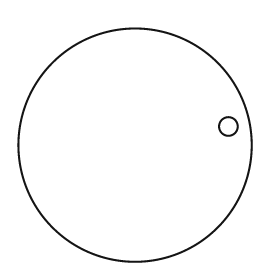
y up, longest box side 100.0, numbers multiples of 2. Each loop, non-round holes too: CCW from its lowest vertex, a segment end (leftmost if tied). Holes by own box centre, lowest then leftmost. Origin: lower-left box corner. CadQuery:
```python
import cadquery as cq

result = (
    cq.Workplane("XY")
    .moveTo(50.0, 50.0)
    .circle(50.0)
    .moveTo(90.0, 58.0)
    .circle(4.0)
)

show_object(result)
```